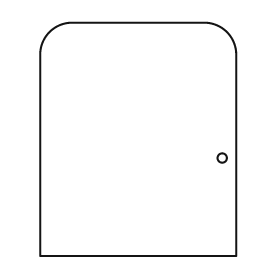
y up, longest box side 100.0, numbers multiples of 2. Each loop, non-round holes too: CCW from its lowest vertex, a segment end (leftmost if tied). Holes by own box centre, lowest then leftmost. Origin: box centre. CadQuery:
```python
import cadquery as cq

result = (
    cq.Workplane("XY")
    .moveTo(-42.0, -50.0)
    .lineTo(42.0, -50.0)
    .lineTo(42.0, 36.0)
    .threePointArc((38.0, 46.0), (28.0, 50.0))
    .lineTo(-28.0, 50.0)
    .threePointArc((-38.0, 46.0), (-42.0, 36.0))
    .close()
    .moveTo(36.0, -8.0)
    .circle(2.0)
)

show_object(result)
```